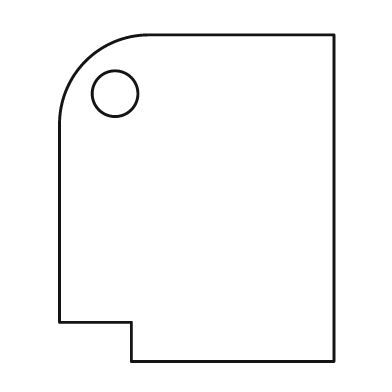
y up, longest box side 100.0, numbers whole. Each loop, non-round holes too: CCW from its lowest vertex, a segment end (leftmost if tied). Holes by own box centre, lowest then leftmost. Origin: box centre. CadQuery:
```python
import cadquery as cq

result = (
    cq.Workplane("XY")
    .moveTo(-20.0, -50.0)
    .lineTo(42.0, -50.0)
    .lineTo(42.0, 50.0)
    .lineTo(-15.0, 50.0)
    .threePointArc((-34.0, 42.0), (-42.0, 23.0))
    .lineTo(-42.0, -38.0)
    .lineTo(-20.0, -38.0)
    .close()
    .moveTo(-25.0, 32.0)
    .circle(7.0)
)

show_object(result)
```